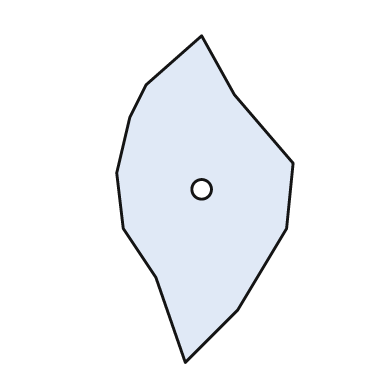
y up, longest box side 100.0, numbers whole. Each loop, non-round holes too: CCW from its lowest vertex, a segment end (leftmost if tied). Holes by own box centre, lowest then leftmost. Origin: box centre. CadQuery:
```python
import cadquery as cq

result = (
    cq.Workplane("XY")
    .moveTo(-6.0, -50.0)
    .lineTo(10.0, -34.0)
    .lineTo(25.0, -9.0)
    .lineTo(27.0, 11.0)
    .lineTo(9.0, 32.0)
    .lineTo(-1.0, 50.0)
    .lineTo(-18.0, 35.0)
    .lineTo(-23.0, 25.0)
    .lineTo(-27.0, 8.0)
    .lineTo(-25.0, -9.0)
    .lineTo(-15.0, -24.0)
    .close()
    .moveTo(-1.0, 3.0)
    .circle(3.0)
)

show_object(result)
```